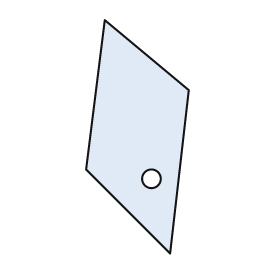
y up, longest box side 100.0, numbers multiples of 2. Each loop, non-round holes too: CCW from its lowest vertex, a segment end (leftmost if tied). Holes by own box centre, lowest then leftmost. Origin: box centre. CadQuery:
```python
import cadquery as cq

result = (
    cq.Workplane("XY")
    .moveTo(14.0, -50.0)
    .lineTo(22.0, 20.0)
    .lineTo(-14.0, 50.0)
    .lineTo(-22.0, -14.0)
    .close()
    .moveTo(6.0, -18.0)
    .circle(4.0)
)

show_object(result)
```